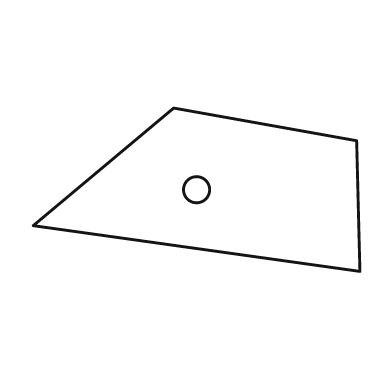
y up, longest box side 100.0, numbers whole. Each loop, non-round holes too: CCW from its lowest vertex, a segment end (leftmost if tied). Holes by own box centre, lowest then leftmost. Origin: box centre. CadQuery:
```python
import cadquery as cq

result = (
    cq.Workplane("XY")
    .moveTo(50.0, -25.0)
    .lineTo(49.0, 15.0)
    .lineTo(-7.0, 25.0)
    .lineTo(-50.0, -11.0)
    .close()
    .moveTo(0.0, 0.0)
    .circle(4.0)
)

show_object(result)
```